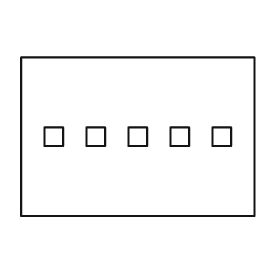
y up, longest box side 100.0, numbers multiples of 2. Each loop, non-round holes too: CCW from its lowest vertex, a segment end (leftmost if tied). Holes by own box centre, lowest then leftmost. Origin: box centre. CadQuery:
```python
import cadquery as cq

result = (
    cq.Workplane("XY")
    .moveTo(-50.0, -34.0)
    .lineTo(50.0, -34.0)
    .lineTo(50.0, 34.0)
    .lineTo(-50.0, 34.0)
    .close()
    .moveTo(-40.0, -4.0)
    .lineTo(-32.0, -4.0)
    .lineTo(-32.0, 4.0)
    .lineTo(-40.0, 4.0)
    .close()
    .moveTo(-22.0, -4.0)
    .lineTo(-14.0, -4.0)
    .lineTo(-14.0, 4.0)
    .lineTo(-22.0, 4.0)
    .close()
    .moveTo(-4.0, -4.0)
    .lineTo(4.0, -4.0)
    .lineTo(4.0, 4.0)
    .lineTo(-4.0, 4.0)
    .close()
    .moveTo(14.0, -4.0)
    .lineTo(22.0, -4.0)
    .lineTo(22.0, 4.0)
    .lineTo(14.0, 4.0)
    .close()
    .moveTo(32.0, -4.0)
    .lineTo(40.0, -4.0)
    .lineTo(40.0, 4.0)
    .lineTo(32.0, 4.0)
    .close()
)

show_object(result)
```